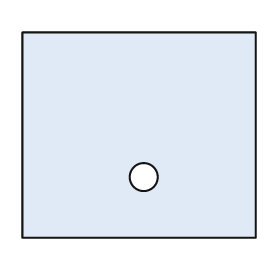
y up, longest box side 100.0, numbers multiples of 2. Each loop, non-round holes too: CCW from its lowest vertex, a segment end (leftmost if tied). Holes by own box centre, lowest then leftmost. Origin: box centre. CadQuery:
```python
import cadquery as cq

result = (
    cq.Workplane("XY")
    .moveTo(-50.0, -44.0)
    .lineTo(50.0, -44.0)
    .lineTo(50.0, 44.0)
    .lineTo(-50.0, 44.0)
    .close()
    .moveTo(2.0, -18.0)
    .circle(6.0)
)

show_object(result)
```